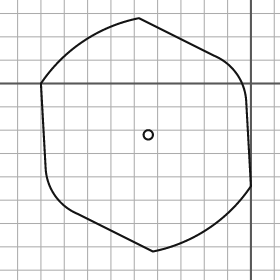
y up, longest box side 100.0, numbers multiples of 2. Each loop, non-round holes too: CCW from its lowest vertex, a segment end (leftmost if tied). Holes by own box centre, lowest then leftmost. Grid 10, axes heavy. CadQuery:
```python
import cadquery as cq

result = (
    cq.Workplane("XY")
    .moveTo(-42.0, -72.0)
    .threePointArc((-18.0, -62.0), (0.0, -44.0))
    .lineTo(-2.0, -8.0)
    .threePointArc((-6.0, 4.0), (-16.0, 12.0))
    .lineTo(-48.0, 28.0)
    .threePointArc((-72.0, 18.0), (-90.0, 0.0))
    .lineTo(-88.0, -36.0)
    .threePointArc((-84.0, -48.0), (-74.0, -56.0))
    .close()
    .moveTo(-44.0, -22.0)
    .circle(2.0)
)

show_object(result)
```